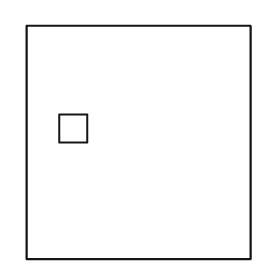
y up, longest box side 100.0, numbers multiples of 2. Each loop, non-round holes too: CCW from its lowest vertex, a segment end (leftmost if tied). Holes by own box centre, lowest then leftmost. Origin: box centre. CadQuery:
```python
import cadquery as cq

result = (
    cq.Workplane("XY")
    .moveTo(-48.0, -50.0)
    .lineTo(48.0, -50.0)
    .lineTo(48.0, 50.0)
    .lineTo(-48.0, 50.0)
    .close()
    .moveTo(-34.0, 0.0)
    .lineTo(-22.0, 0.0)
    .lineTo(-22.0, 12.0)
    .lineTo(-34.0, 12.0)
    .close()
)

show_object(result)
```